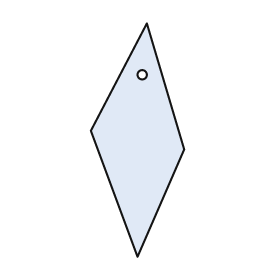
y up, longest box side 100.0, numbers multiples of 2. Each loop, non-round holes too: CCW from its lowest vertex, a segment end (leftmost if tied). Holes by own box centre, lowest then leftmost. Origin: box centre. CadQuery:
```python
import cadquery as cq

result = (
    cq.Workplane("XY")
    .moveTo(0.0, -50.0)
    .lineTo(20.0, -4.0)
    .lineTo(4.0, 50.0)
    .lineTo(-20.0, 4.0)
    .close()
    .moveTo(2.0, 28.0)
    .circle(2.0)
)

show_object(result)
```